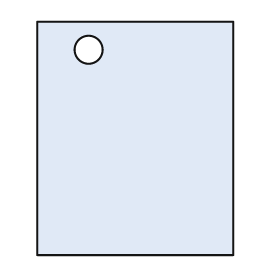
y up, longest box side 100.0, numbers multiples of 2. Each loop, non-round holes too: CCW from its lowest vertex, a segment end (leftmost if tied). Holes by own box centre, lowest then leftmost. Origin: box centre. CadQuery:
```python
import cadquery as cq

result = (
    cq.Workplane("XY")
    .moveTo(-42.0, -50.0)
    .lineTo(42.0, -50.0)
    .lineTo(42.0, 50.0)
    .lineTo(-42.0, 50.0)
    .close()
    .moveTo(-20.0, 38.0)
    .circle(6.0)
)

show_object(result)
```